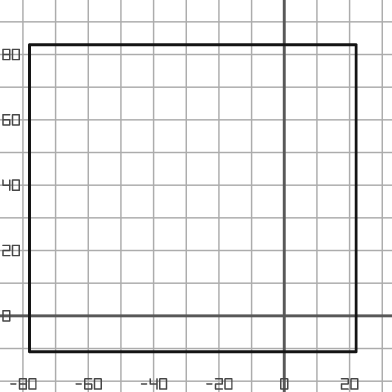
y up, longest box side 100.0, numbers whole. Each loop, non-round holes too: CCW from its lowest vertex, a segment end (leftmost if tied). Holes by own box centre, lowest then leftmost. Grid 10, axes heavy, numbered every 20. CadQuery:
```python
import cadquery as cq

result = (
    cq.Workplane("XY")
    .moveTo(-78.0, -11.0)
    .lineTo(22.0, -11.0)
    .lineTo(22.0, 83.0)
    .lineTo(-78.0, 83.0)
    .close()
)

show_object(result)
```